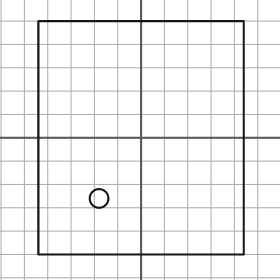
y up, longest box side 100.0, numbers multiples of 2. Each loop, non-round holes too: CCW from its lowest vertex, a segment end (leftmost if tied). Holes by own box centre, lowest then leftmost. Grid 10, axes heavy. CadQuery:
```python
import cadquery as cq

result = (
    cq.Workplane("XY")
    .moveTo(-44.0, -50.0)
    .lineTo(44.0, -50.0)
    .lineTo(44.0, 50.0)
    .lineTo(-44.0, 50.0)
    .close()
    .moveTo(-18.0, -26.0)
    .circle(4.0)
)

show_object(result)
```